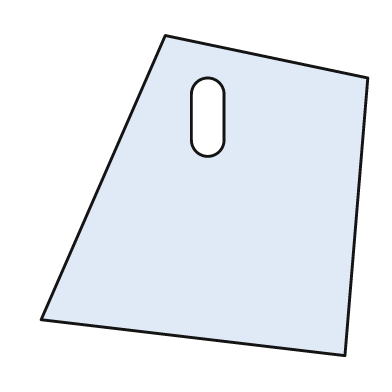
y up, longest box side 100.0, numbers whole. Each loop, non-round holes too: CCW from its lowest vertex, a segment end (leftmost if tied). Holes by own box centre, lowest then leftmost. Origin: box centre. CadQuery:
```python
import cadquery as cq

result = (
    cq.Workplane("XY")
    .moveTo(43.0, -49.0)
    .lineTo(50.0, 36.0)
    .lineTo(-12.0, 49.0)
    .lineTo(-50.0, -38.0)
    .close()
    .moveTo(-4.0, 17.0)
    .threePointArc((1.0, 12.0), (6.0, 17.0))
    .lineTo(6.0, 31.0)
    .threePointArc((1.0, 36.0), (-4.0, 31.0))
    .close()
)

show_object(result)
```